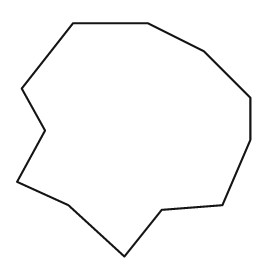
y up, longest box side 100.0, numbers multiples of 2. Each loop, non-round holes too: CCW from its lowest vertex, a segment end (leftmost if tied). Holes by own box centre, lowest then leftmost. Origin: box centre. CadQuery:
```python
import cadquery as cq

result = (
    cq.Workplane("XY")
    .moveTo(-4.0, -50.0)
    .lineTo(12.0, -30.0)
    .lineTo(38.0, -28.0)
    .lineTo(50.0, 0.0)
    .lineTo(50.0, 18.0)
    .lineTo(30.0, 38.0)
    .lineTo(6.0, 50.0)
    .lineTo(-26.0, 50.0)
    .lineTo(-48.0, 22.0)
    .lineTo(-38.0, 4.0)
    .lineTo(-50.0, -18.0)
    .lineTo(-28.0, -28.0)
    .close()
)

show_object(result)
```